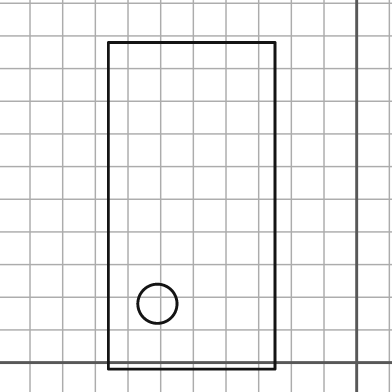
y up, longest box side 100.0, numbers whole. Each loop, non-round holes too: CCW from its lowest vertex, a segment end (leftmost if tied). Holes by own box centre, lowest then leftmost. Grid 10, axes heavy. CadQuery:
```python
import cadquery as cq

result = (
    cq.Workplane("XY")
    .moveTo(-76.0, -2.0)
    .lineTo(-25.0, -2.0)
    .lineTo(-25.0, 98.0)
    .lineTo(-76.0, 98.0)
    .close()
    .moveTo(-61.0, 18.0)
    .circle(6.0)
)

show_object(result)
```